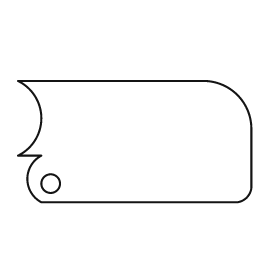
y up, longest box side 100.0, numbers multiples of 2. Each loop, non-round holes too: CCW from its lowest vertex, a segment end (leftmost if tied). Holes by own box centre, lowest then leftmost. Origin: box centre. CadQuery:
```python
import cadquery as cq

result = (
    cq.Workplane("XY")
    .moveTo(-40.0, -26.0)
    .lineTo(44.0, -26.0)
    .threePointArc((48.0, -24.0), (50.0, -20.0))
    .lineTo(50.0, 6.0)
    .threePointArc((44.0, 20.0), (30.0, 26.0))
    .lineTo(-50.0, 26.0)
    .threePointArc((-40.0, 10.0), (-50.0, -6.0))
    .lineTo(-40.0, -6.0)
    .threePointArc((-46.0, -16.0), (-40.0, -26.0))
    .close()
    .moveTo(-36.0, -18.0)
    .circle(4.0)
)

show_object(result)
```